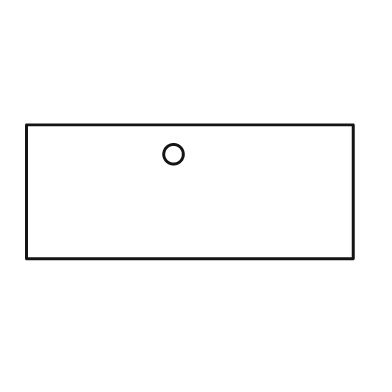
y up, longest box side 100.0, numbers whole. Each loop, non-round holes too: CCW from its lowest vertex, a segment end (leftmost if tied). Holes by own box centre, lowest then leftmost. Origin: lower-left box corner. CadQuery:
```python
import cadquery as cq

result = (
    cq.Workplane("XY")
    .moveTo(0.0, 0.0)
    .lineTo(100.0, 0.0)
    .lineTo(100.0, 41.0)
    .lineTo(0.0, 41.0)
    .close()
    .moveTo(45.0, 32.0)
    .circle(3.0)
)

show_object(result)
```